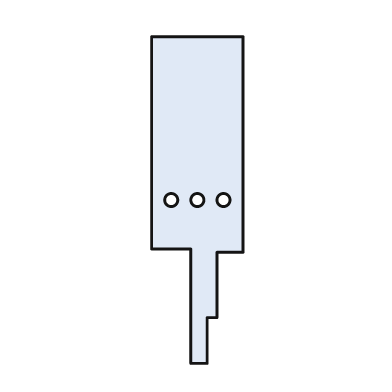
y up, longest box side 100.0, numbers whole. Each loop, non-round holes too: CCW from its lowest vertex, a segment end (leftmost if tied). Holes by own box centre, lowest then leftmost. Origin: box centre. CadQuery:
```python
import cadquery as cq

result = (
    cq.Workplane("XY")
    .moveTo(-2.0, -50.0)
    .lineTo(3.0, -50.0)
    .lineTo(3.0, -36.0)
    .lineTo(6.0, -36.0)
    .lineTo(6.0, -16.0)
    .lineTo(14.0, -16.0)
    .lineTo(14.0, 50.0)
    .lineTo(-14.0, 50.0)
    .lineTo(-14.0, -15.0)
    .lineTo(-2.0, -15.0)
    .close()
    .moveTo(-8.0, 0.0)
    .circle(2.0)
    .moveTo(0.0, 0.0)
    .circle(2.0)
    .moveTo(8.0, 0.0)
    .circle(2.0)
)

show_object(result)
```